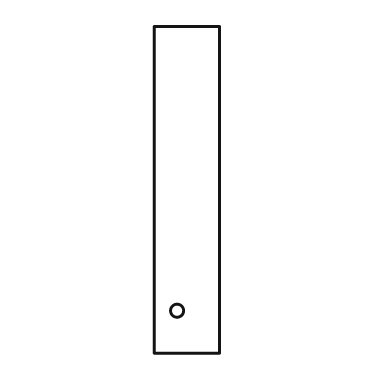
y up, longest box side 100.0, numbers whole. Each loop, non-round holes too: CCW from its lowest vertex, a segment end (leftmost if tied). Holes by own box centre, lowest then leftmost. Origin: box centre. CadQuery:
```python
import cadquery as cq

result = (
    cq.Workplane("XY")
    .moveTo(-10.0, -50.0)
    .lineTo(10.0, -50.0)
    .lineTo(10.0, 50.0)
    .lineTo(-10.0, 50.0)
    .close()
    .moveTo(-3.0, -37.0)
    .circle(2.0)
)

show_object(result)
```